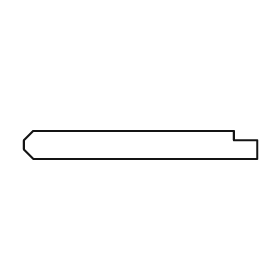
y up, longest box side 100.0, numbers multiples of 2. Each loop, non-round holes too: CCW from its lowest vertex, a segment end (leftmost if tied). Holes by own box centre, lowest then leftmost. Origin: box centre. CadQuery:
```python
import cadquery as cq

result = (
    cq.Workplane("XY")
    .moveTo(-46.0, -6.0)
    .lineTo(50.0, -6.0)
    .lineTo(50.0, 2.0)
    .lineTo(40.0, 2.0)
    .lineTo(40.0, 6.0)
    .lineTo(-46.0, 6.0)
    .lineTo(-50.0, 2.0)
    .lineTo(-50.0, -2.0)
    .close()
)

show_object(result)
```